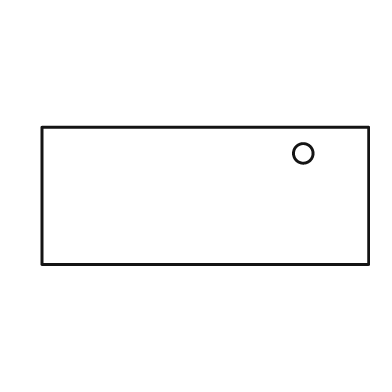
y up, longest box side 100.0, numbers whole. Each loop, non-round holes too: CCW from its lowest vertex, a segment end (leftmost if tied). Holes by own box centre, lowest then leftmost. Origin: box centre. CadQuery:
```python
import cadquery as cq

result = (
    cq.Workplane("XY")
    .moveTo(-50.0, -21.0)
    .lineTo(50.0, -21.0)
    .lineTo(50.0, 21.0)
    .lineTo(-50.0, 21.0)
    .close()
    .moveTo(30.0, 13.0)
    .circle(3.0)
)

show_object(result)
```